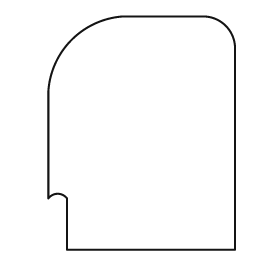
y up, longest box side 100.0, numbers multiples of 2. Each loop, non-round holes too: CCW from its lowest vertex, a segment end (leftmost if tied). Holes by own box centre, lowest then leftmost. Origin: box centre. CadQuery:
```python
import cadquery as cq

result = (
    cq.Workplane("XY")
    .moveTo(-32.0, -50.0)
    .lineTo(40.0, -50.0)
    .lineTo(40.0, 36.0)
    .threePointArc((36.0, 46.0), (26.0, 50.0))
    .lineTo(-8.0, 50.0)
    .threePointArc((-30.0, 40.0), (-40.0, 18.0))
    .lineTo(-40.0, -28.0)
    .threePointArc((-36.0, -26.0), (-32.0, -28.0))
    .close()
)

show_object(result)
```